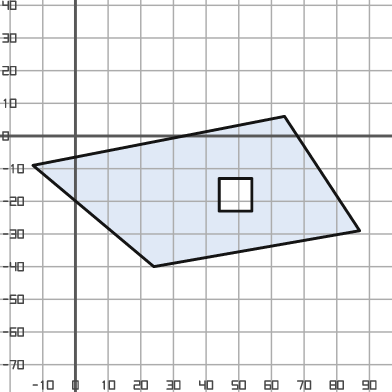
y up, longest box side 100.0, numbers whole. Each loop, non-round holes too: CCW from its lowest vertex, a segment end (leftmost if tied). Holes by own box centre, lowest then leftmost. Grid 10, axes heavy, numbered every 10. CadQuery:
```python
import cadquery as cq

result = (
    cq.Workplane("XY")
    .moveTo(24.0, -40.0)
    .lineTo(87.0, -29.0)
    .lineTo(64.0, 6.0)
    .lineTo(-13.0, -9.0)
    .close()
    .moveTo(44.0, -23.0)
    .lineTo(54.0, -23.0)
    .lineTo(54.0, -13.0)
    .lineTo(44.0, -13.0)
    .close()
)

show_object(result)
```